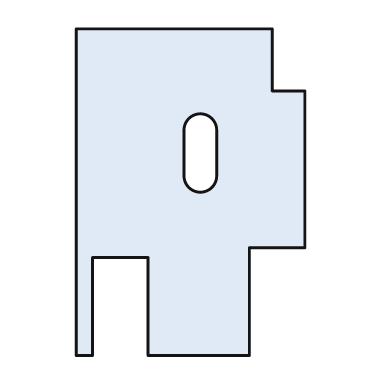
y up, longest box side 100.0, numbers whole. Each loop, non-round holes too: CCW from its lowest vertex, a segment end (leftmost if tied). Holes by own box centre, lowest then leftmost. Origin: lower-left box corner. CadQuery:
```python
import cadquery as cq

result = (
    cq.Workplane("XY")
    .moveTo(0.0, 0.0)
    .lineTo(5.0, 0.0)
    .lineTo(5.0, 30.0)
    .lineTo(22.0, 30.0)
    .lineTo(22.0, 0.0)
    .lineTo(53.0, 0.0)
    .lineTo(53.0, 33.0)
    .lineTo(70.0, 33.0)
    .lineTo(70.0, 81.0)
    .lineTo(60.0, 81.0)
    .lineTo(60.0, 100.0)
    .lineTo(0.0, 100.0)
    .close()
    .moveTo(33.0, 55.0)
    .threePointArc((38.0, 50.0), (43.0, 55.0))
    .lineTo(43.0, 69.0)
    .threePointArc((38.0, 74.0), (33.0, 69.0))
    .close()
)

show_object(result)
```